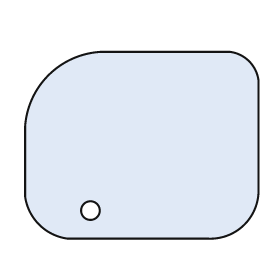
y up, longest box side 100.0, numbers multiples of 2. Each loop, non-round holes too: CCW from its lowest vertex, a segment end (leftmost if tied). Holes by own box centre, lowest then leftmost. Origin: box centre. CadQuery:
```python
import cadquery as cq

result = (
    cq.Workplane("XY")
    .moveTo(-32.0, -40.0)
    .lineTo(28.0, -40.0)
    .threePointArc((44.0, -34.0), (50.0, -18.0))
    .lineTo(50.0, 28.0)
    .threePointArc((46.0, 36.0), (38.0, 40.0))
    .lineTo(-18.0, 40.0)
    .threePointArc((-40.0, 30.0), (-50.0, 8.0))
    .lineTo(-50.0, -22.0)
    .threePointArc((-44.0, -34.0), (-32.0, -40.0))
    .close()
    .moveTo(-22.0, -28.0)
    .circle(4.0)
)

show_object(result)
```